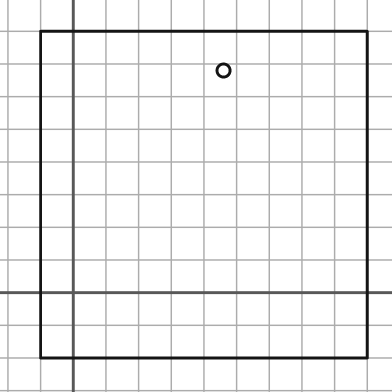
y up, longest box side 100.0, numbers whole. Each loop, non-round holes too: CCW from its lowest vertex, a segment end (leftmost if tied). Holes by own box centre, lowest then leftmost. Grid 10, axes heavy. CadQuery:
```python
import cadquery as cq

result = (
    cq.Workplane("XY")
    .moveTo(-10.0, -20.0)
    .lineTo(90.0, -20.0)
    .lineTo(90.0, 80.0)
    .lineTo(-10.0, 80.0)
    .close()
    .moveTo(46.0, 68.0)
    .circle(2.0)
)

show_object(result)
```